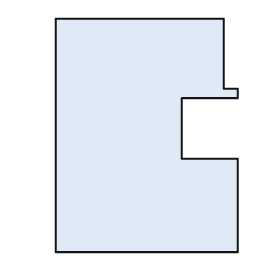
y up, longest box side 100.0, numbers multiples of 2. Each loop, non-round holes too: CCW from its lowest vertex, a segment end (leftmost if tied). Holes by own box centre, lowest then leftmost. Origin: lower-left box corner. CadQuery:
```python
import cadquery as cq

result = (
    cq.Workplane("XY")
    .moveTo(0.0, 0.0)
    .lineTo(78.0, 0.0)
    .lineTo(78.0, 40.0)
    .lineTo(54.0, 40.0)
    .lineTo(54.0, 66.0)
    .lineTo(78.0, 66.0)
    .lineTo(78.0, 70.0)
    .lineTo(72.0, 70.0)
    .lineTo(72.0, 100.0)
    .lineTo(0.0, 100.0)
    .close()
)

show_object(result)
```